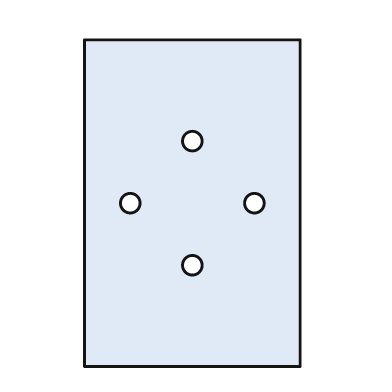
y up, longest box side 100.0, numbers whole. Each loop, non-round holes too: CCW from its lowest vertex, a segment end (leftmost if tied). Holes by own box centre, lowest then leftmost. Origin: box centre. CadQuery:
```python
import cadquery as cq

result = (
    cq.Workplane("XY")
    .moveTo(-33.0, -50.0)
    .lineTo(33.0, -50.0)
    .lineTo(33.0, 50.0)
    .lineTo(-33.0, 50.0)
    .close()
    .moveTo(0.0, -19.0)
    .circle(3.0)
    .moveTo(-19.0, 0.0)
    .circle(3.0)
    .moveTo(19.0, 0.0)
    .circle(3.0)
    .moveTo(0.0, 19.0)
    .circle(3.0)
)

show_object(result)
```